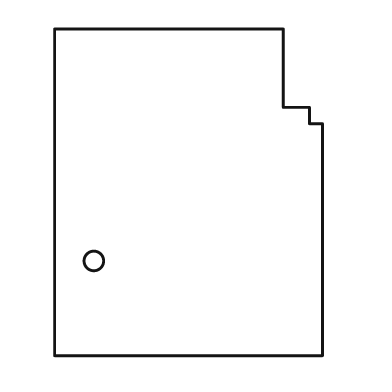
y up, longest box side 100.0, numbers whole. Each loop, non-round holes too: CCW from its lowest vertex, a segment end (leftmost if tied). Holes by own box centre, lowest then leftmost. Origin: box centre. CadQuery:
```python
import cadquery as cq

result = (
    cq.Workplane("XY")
    .moveTo(-41.0, -50.0)
    .lineTo(41.0, -50.0)
    .lineTo(41.0, 21.0)
    .lineTo(37.0, 21.0)
    .lineTo(37.0, 26.0)
    .lineTo(29.0, 26.0)
    .lineTo(29.0, 50.0)
    .lineTo(-41.0, 50.0)
    .close()
    .moveTo(-29.0, -21.0)
    .circle(3.0)
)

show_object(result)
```